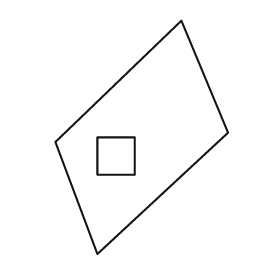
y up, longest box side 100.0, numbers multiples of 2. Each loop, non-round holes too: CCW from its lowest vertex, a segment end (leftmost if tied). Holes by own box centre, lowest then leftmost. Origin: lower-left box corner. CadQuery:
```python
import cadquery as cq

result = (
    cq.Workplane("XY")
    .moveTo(18.0, 0.0)
    .lineTo(74.0, 52.0)
    .lineTo(54.0, 100.0)
    .lineTo(0.0, 48.0)
    .close()
    .moveTo(18.0, 34.0)
    .lineTo(34.0, 34.0)
    .lineTo(34.0, 50.0)
    .lineTo(18.0, 50.0)
    .close()
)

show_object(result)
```